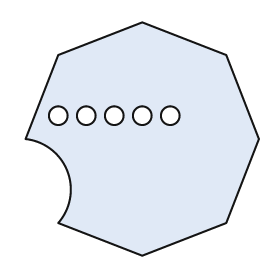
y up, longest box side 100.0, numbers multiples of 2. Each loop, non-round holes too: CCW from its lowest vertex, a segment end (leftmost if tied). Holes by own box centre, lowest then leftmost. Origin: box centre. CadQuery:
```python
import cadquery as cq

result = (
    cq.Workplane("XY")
    .moveTo(0.0, -50.0)
    .lineTo(36.0, -36.0)
    .lineTo(50.0, 0.0)
    .lineTo(36.0, 36.0)
    .lineTo(0.0, 50.0)
    .lineTo(-36.0, 36.0)
    .lineTo(-50.0, 0.0)
    .threePointArc((-32.0, -14.0), (-36.0, -36.0))
    .close()
    .moveTo(-36.0, 10.0)
    .circle(4.0)
    .moveTo(-24.0, 10.0)
    .circle(4.0)
    .moveTo(-12.0, 10.0)
    .circle(4.0)
    .moveTo(0.0, 10.0)
    .circle(4.0)
    .moveTo(12.0, 10.0)
    .circle(4.0)
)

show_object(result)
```